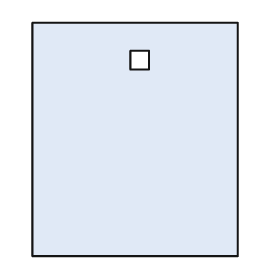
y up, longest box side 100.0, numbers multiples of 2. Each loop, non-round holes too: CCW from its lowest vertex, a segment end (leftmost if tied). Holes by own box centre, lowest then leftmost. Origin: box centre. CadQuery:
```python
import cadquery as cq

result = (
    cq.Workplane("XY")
    .moveTo(-44.0, -50.0)
    .lineTo(44.0, -50.0)
    .lineTo(44.0, 50.0)
    .lineTo(-44.0, 50.0)
    .close()
    .moveTo(-2.0, 30.0)
    .lineTo(6.0, 30.0)
    .lineTo(6.0, 38.0)
    .lineTo(-2.0, 38.0)
    .close()
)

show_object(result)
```